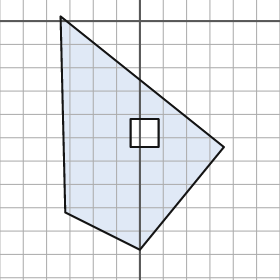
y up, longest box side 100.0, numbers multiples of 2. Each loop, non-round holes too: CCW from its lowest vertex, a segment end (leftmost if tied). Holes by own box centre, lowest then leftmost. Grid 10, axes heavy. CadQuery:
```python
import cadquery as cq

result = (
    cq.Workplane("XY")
    .moveTo(0.0, -98.0)
    .lineTo(36.0, -54.0)
    .lineTo(-34.0, 2.0)
    .lineTo(-32.0, -82.0)
    .close()
    .moveTo(-4.0, -54.0)
    .lineTo(8.0, -54.0)
    .lineTo(8.0, -42.0)
    .lineTo(-4.0, -42.0)
    .close()
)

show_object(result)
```